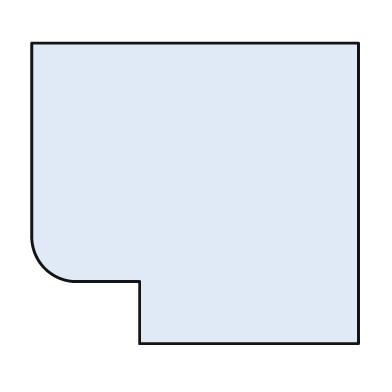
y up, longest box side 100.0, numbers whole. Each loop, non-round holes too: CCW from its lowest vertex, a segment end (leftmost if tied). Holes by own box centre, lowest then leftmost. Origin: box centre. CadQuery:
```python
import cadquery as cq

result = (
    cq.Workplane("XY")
    .moveTo(-17.0, -46.0)
    .lineTo(50.0, -46.0)
    .lineTo(50.0, 46.0)
    .lineTo(-50.0, 46.0)
    .lineTo(-50.0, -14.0)
    .threePointArc((-46.0, -23.0), (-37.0, -27.0))
    .lineTo(-17.0, -27.0)
    .close()
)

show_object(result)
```